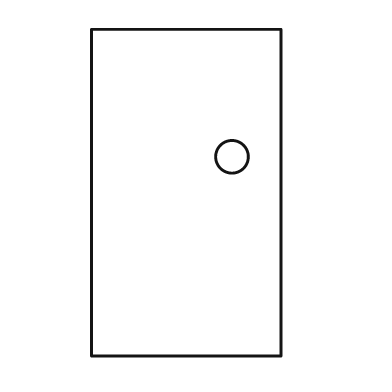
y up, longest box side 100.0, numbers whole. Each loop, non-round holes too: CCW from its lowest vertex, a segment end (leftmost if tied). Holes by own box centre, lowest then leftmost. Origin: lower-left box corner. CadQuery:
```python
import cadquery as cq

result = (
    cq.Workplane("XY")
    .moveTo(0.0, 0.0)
    .lineTo(58.0, 0.0)
    .lineTo(58.0, 100.0)
    .lineTo(0.0, 100.0)
    .close()
    .moveTo(43.0, 61.0)
    .circle(5.0)
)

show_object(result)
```